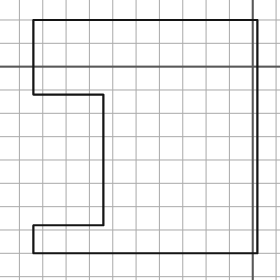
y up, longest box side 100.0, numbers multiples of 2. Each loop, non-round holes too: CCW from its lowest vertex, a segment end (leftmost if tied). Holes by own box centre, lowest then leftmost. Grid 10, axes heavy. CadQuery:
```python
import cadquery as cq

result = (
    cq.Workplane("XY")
    .moveTo(-94.0, -80.0)
    .lineTo(2.0, -80.0)
    .lineTo(2.0, 20.0)
    .lineTo(-94.0, 20.0)
    .lineTo(-94.0, -12.0)
    .lineTo(-64.0, -12.0)
    .lineTo(-64.0, -68.0)
    .lineTo(-94.0, -68.0)
    .close()
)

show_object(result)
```